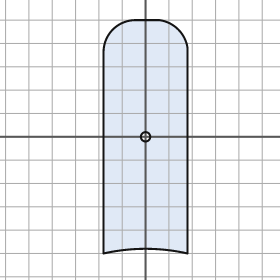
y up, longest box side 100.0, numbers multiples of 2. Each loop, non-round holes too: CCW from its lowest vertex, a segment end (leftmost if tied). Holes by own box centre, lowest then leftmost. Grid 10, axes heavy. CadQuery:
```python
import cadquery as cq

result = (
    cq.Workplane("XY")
    .moveTo(-18.0, -50.0)
    .threePointArc((0.0, -48.0), (18.0, -50.0))
    .lineTo(18.0, 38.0)
    .threePointArc((14.0, 46.0), (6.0, 50.0))
    .lineTo(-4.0, 50.0)
    .threePointArc((-14.0, 46.0), (-18.0, 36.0))
    .close()
    .moveTo(0.0, 0.0)
    .circle(2.0)
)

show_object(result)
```